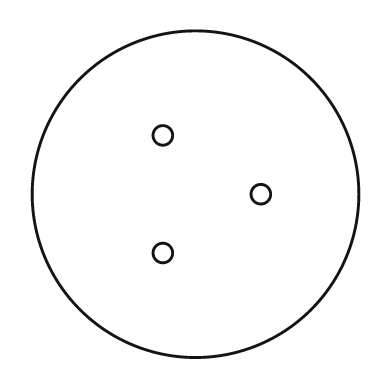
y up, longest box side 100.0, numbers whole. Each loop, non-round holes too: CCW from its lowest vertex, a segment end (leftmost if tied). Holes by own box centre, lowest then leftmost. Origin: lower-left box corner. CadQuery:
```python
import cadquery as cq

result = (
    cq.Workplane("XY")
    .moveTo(50.0, 50.0)
    .circle(50.0)
    .moveTo(40.0, 32.0)
    .circle(3.0)
    .moveTo(70.0, 50.0)
    .circle(3.0)
    .moveTo(40.0, 68.0)
    .circle(3.0)
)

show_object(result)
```